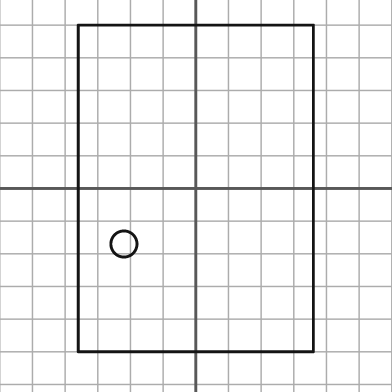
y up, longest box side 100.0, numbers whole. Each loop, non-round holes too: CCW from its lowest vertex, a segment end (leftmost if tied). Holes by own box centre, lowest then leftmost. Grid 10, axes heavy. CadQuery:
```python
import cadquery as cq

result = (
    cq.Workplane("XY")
    .moveTo(-36.0, -50.0)
    .lineTo(36.0, -50.0)
    .lineTo(36.0, 50.0)
    .lineTo(-36.0, 50.0)
    .close()
    .moveTo(-22.0, -17.0)
    .circle(4.0)
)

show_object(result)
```